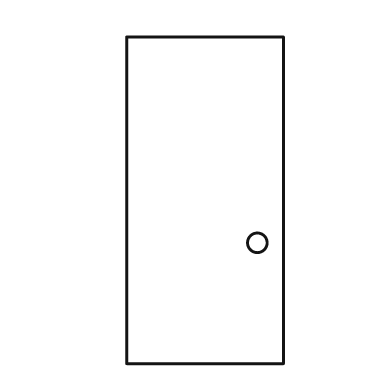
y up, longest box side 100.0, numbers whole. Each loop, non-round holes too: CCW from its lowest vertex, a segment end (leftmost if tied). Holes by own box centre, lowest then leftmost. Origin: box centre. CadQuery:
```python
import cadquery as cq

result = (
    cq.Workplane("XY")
    .moveTo(-24.0, -50.0)
    .lineTo(24.0, -50.0)
    .lineTo(24.0, 50.0)
    .lineTo(-24.0, 50.0)
    .close()
    .moveTo(16.0, -13.0)
    .circle(3.0)
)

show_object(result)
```